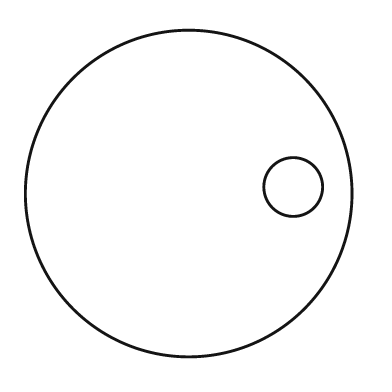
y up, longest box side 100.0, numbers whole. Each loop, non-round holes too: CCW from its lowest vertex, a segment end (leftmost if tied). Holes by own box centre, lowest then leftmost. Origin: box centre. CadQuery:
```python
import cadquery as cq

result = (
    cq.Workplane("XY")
    .moveTo(0.0, 0.0)
    .circle(50.0)
    .moveTo(32.0, 2.0)
    .circle(9.0)
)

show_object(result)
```